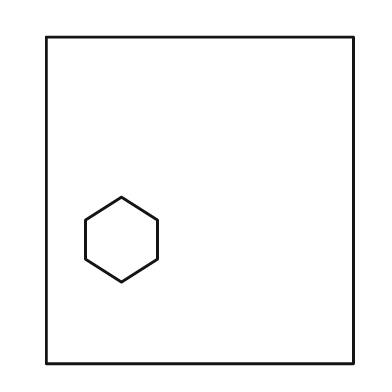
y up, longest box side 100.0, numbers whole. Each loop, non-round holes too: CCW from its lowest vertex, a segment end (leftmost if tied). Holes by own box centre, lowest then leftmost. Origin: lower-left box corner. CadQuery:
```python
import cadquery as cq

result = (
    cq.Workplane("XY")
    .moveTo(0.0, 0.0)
    .lineTo(94.0, 0.0)
    .lineTo(94.0, 100.0)
    .lineTo(0.0, 100.0)
    .close()
    .moveTo(23.0, 25.0)
    .lineTo(34.0, 32.0)
    .lineTo(34.0, 44.0)
    .lineTo(23.0, 51.0)
    .lineTo(12.0, 44.0)
    .lineTo(12.0, 32.0)
    .close()
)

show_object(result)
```